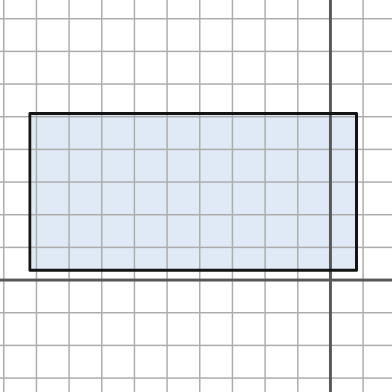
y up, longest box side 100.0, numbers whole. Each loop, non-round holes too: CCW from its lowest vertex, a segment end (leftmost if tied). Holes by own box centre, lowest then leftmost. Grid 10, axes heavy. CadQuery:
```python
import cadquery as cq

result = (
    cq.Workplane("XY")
    .moveTo(-92.0, 3.0)
    .lineTo(8.0, 3.0)
    .lineTo(8.0, 51.0)
    .lineTo(-92.0, 51.0)
    .close()
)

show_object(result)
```